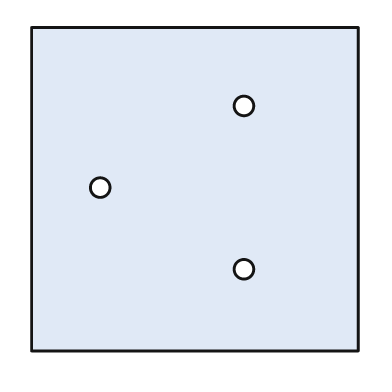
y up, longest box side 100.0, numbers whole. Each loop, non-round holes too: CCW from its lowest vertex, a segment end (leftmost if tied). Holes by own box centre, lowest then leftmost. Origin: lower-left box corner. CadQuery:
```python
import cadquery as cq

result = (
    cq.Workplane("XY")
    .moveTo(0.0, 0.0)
    .lineTo(100.0, 0.0)
    .lineTo(100.0, 99.0)
    .lineTo(0.0, 99.0)
    .close()
    .moveTo(65.0, 25.0)
    .circle(3.0)
    .moveTo(21.0, 50.0)
    .circle(3.0)
    .moveTo(65.0, 75.0)
    .circle(3.0)
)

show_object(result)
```